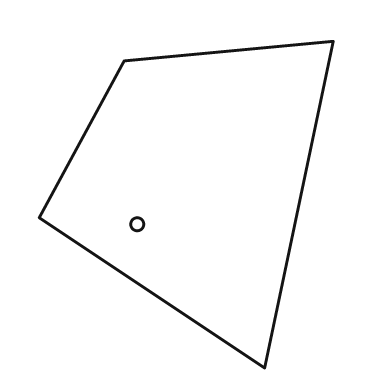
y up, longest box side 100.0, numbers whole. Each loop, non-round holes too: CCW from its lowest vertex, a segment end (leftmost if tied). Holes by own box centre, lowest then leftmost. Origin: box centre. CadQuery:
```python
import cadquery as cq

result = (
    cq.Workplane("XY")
    .moveTo(24.0, -50.0)
    .lineTo(45.0, 50.0)
    .lineTo(-19.0, 44.0)
    .lineTo(-45.0, -4.0)
    .close()
    .moveTo(-15.0, -6.0)
    .circle(2.0)
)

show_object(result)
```